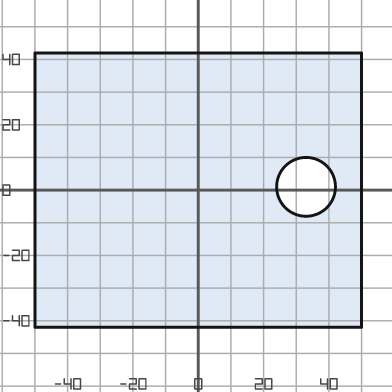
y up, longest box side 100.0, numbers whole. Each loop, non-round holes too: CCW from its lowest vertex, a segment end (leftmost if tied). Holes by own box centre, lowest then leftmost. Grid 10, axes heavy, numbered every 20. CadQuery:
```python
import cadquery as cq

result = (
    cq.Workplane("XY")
    .moveTo(-50.0, -42.0)
    .lineTo(50.0, -42.0)
    .lineTo(50.0, 42.0)
    .lineTo(-50.0, 42.0)
    .close()
    .moveTo(33.0, 1.0)
    .circle(9.0)
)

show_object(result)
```